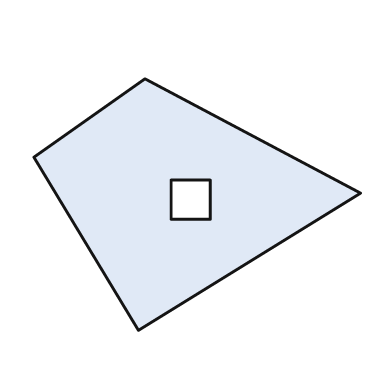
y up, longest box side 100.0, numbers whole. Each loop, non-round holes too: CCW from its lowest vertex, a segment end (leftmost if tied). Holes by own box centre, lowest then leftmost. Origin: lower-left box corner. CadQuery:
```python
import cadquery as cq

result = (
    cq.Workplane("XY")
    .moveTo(32.0, 0.0)
    .lineTo(100.0, 42.0)
    .lineTo(34.0, 77.0)
    .lineTo(0.0, 53.0)
    .close()
    .moveTo(42.0, 34.0)
    .lineTo(54.0, 34.0)
    .lineTo(54.0, 46.0)
    .lineTo(42.0, 46.0)
    .close()
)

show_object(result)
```